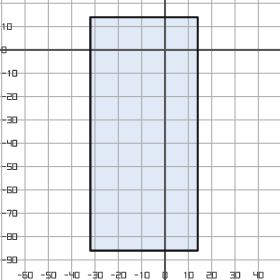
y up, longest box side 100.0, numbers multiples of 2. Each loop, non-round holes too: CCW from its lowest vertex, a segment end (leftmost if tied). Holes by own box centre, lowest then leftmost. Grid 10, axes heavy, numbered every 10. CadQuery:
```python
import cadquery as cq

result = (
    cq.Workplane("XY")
    .moveTo(-32.0, -86.0)
    .lineTo(14.0, -86.0)
    .lineTo(14.0, 14.0)
    .lineTo(-32.0, 14.0)
    .close()
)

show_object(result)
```